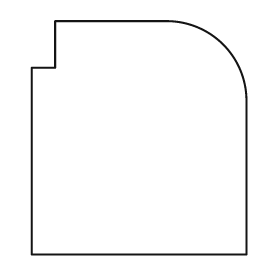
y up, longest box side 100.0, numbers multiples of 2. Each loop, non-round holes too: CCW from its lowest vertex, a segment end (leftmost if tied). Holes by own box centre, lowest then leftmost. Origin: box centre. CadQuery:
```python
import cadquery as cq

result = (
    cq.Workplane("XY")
    .moveTo(-46.0, -50.0)
    .lineTo(46.0, -50.0)
    .lineTo(46.0, 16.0)
    .threePointArc((36.0, 40.0), (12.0, 50.0))
    .lineTo(-36.0, 50.0)
    .lineTo(-36.0, 30.0)
    .lineTo(-46.0, 30.0)
    .close()
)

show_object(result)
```